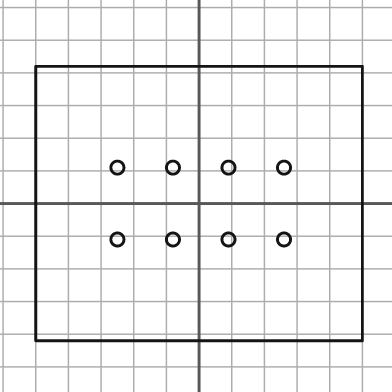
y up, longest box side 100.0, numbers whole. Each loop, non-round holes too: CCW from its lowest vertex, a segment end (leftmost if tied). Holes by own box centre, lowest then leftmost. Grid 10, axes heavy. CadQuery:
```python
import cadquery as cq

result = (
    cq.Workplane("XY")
    .moveTo(-50.0, -42.0)
    .lineTo(50.0, -42.0)
    .lineTo(50.0, 42.0)
    .lineTo(-50.0, 42.0)
    .close()
    .moveTo(-25.0, -11.0)
    .circle(2.0)
    .moveTo(-8.0, -11.0)
    .circle(2.0)
    .moveTo(9.0, -11.0)
    .circle(2.0)
    .moveTo(26.0, -11.0)
    .circle(2.0)
    .moveTo(-25.0, 11.0)
    .circle(2.0)
    .moveTo(-8.0, 11.0)
    .circle(2.0)
    .moveTo(9.0, 11.0)
    .circle(2.0)
    .moveTo(26.0, 11.0)
    .circle(2.0)
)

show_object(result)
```